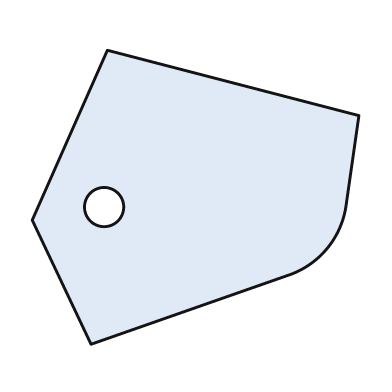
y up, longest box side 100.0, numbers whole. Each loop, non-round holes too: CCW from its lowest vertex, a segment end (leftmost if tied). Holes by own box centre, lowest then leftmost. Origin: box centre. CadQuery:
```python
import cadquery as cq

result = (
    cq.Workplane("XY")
    .moveTo(-32.0, -45.0)
    .lineTo(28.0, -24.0)
    .threePointArc((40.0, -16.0), (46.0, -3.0))
    .lineTo(50.0, 25.0)
    .lineTo(-27.0, 45.0)
    .lineTo(-50.0, -7.0)
    .close()
    .moveTo(-28.0, -3.0)
    .circle(6.0)
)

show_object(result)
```